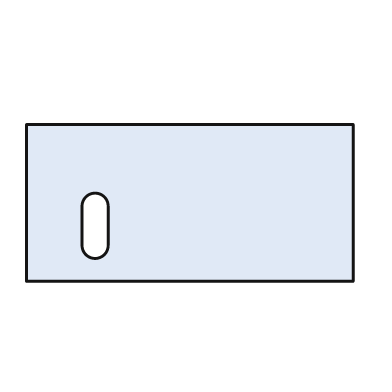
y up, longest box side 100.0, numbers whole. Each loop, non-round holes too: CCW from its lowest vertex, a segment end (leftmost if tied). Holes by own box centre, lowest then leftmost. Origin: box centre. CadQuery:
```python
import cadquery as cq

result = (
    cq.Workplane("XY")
    .moveTo(-50.0, -24.0)
    .lineTo(50.0, -24.0)
    .lineTo(50.0, 24.0)
    .lineTo(-50.0, 24.0)
    .close()
    .moveTo(-33.0, -13.0)
    .threePointArc((-29.0, -17.0), (-25.0, -13.0))
    .lineTo(-25.0, -1.0)
    .threePointArc((-29.0, 3.0), (-33.0, -1.0))
    .close()
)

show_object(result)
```